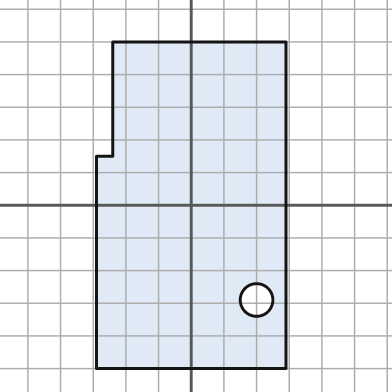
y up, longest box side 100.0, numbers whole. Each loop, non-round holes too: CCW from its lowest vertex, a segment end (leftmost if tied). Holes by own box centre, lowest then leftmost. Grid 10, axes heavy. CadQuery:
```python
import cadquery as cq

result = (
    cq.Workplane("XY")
    .moveTo(-29.0, -50.0)
    .lineTo(29.0, -50.0)
    .lineTo(29.0, 50.0)
    .lineTo(-24.0, 50.0)
    .lineTo(-24.0, 15.0)
    .lineTo(-29.0, 15.0)
    .close()
    .moveTo(20.0, -29.0)
    .circle(5.0)
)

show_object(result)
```